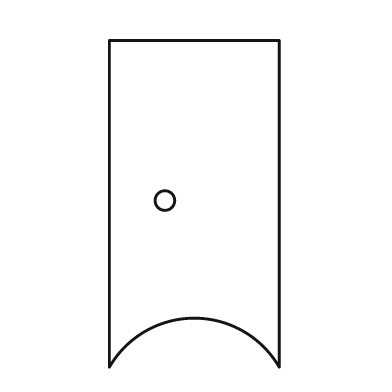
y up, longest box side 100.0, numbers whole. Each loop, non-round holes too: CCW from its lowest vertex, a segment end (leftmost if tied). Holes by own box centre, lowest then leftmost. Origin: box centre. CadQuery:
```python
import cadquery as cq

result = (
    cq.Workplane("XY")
    .moveTo(-26.0, -50.0)
    .threePointArc((0.0, -35.0), (26.0, -50.0))
    .lineTo(26.0, 50.0)
    .lineTo(-26.0, 50.0)
    .close()
    .moveTo(-9.0, 1.0)
    .circle(3.0)
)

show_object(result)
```